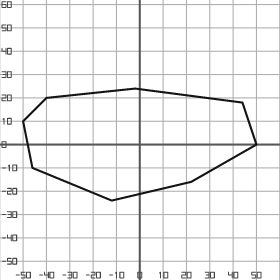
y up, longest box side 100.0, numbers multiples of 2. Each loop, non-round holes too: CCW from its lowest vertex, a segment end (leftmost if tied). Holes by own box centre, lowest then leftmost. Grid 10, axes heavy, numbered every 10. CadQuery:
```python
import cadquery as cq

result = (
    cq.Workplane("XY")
    .moveTo(-12.0, -24.0)
    .lineTo(22.0, -16.0)
    .lineTo(50.0, 0.0)
    .lineTo(44.0, 18.0)
    .lineTo(-2.0, 24.0)
    .lineTo(-40.0, 20.0)
    .lineTo(-50.0, 10.0)
    .lineTo(-46.0, -10.0)
    .close()
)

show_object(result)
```